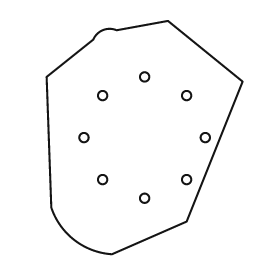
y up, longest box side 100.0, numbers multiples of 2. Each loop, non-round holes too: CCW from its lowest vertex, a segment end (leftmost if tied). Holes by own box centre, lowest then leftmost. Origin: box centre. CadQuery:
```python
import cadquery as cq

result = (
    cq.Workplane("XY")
    .moveTo(-14.0, -50.0)
    .lineTo(18.0, -36.0)
    .lineTo(42.0, 24.0)
    .lineTo(10.0, 50.0)
    .lineTo(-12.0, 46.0)
    .threePointArc((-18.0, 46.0), (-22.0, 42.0))
    .lineTo(-42.0, 26.0)
    .lineTo(-40.0, -30.0)
    .threePointArc((-30.0, -44.0), (-14.0, -50.0))
    .close()
    .moveTo(0.0, -26.0)
    .circle(2.0)
    .moveTo(-18.0, -18.0)
    .circle(2.0)
    .moveTo(18.0, -18.0)
    .circle(2.0)
    .moveTo(-26.0, 0.0)
    .circle(2.0)
    .moveTo(26.0, 0.0)
    .circle(2.0)
    .moveTo(-18.0, 18.0)
    .circle(2.0)
    .moveTo(18.0, 18.0)
    .circle(2.0)
    .moveTo(0.0, 26.0)
    .circle(2.0)
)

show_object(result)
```